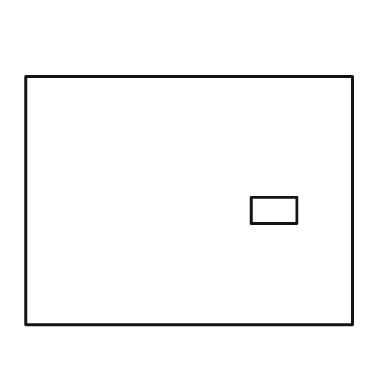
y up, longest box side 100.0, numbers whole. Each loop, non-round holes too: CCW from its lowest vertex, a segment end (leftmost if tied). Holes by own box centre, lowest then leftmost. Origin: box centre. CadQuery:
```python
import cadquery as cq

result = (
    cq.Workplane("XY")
    .moveTo(-50.0, -38.0)
    .lineTo(50.0, -38.0)
    .lineTo(50.0, 38.0)
    .lineTo(-50.0, 38.0)
    .close()
    .moveTo(19.0, -7.0)
    .lineTo(33.0, -7.0)
    .lineTo(33.0, 1.0)
    .lineTo(19.0, 1.0)
    .close()
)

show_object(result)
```